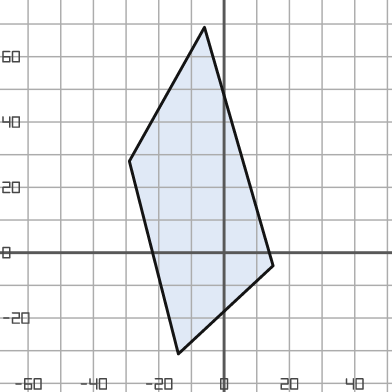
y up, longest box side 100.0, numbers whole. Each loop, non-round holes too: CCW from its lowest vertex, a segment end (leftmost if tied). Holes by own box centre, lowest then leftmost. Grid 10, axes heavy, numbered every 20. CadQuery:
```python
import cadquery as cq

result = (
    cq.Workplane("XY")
    .moveTo(-14.0, -31.0)
    .lineTo(15.0, -4.0)
    .lineTo(-6.0, 69.0)
    .lineTo(-29.0, 28.0)
    .close()
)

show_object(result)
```